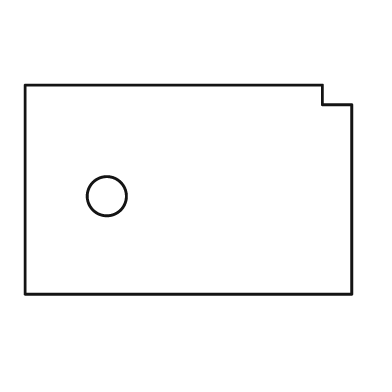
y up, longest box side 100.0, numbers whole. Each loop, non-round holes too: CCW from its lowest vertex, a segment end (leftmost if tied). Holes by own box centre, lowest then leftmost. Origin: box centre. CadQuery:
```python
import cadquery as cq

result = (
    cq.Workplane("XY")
    .moveTo(-50.0, -32.0)
    .lineTo(50.0, -32.0)
    .lineTo(50.0, 26.0)
    .lineTo(41.0, 26.0)
    .lineTo(41.0, 32.0)
    .lineTo(-50.0, 32.0)
    .close()
    .moveTo(-25.0, -2.0)
    .circle(6.0)
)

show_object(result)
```